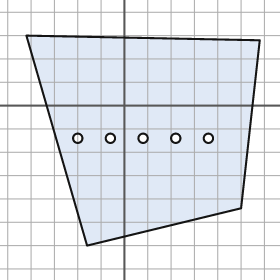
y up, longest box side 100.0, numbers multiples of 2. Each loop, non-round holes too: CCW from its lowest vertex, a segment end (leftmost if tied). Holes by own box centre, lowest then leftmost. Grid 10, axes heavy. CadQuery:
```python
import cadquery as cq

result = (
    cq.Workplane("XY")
    .moveTo(-16.0, -60.0)
    .lineTo(50.0, -44.0)
    .lineTo(58.0, 28.0)
    .lineTo(-42.0, 30.0)
    .close()
    .moveTo(-20.0, -14.0)
    .circle(2.0)
    .moveTo(-6.0, -14.0)
    .circle(2.0)
    .moveTo(8.0, -14.0)
    .circle(2.0)
    .moveTo(22.0, -14.0)
    .circle(2.0)
    .moveTo(36.0, -14.0)
    .circle(2.0)
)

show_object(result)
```